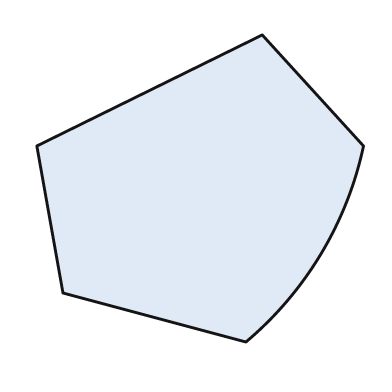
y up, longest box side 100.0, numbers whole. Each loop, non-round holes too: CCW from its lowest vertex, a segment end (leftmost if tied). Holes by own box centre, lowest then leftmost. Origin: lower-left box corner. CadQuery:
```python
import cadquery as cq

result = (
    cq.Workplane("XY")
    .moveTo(64.0, 0.0)
    .threePointArc((87.0, 27.0), (100.0, 60.0))
    .lineTo(69.0, 94.0)
    .lineTo(0.0, 60.0)
    .lineTo(8.0, 15.0)
    .close()
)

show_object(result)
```